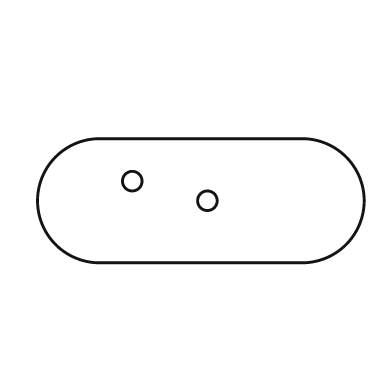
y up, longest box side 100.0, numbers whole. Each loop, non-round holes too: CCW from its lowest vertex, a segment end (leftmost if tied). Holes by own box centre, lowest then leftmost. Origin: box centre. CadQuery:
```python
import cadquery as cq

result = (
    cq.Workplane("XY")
    .moveTo(-31.0, -19.0)
    .lineTo(31.0, -19.0)
    .threePointArc((50.0, 0.0), (31.0, 19.0))
    .lineTo(-31.0, 19.0)
    .threePointArc((-50.0, 0.0), (-31.0, -19.0))
    .close()
    .moveTo(2.0, 0.0)
    .circle(3.0)
    .moveTo(-21.0, 6.0)
    .circle(3.0)
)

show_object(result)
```